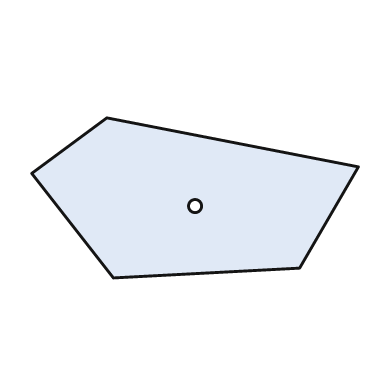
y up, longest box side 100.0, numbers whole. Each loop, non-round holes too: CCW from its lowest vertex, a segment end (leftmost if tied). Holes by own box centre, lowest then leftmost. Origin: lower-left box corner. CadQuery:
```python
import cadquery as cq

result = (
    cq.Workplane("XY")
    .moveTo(25.0, 0.0)
    .lineTo(82.0, 3.0)
    .lineTo(100.0, 34.0)
    .lineTo(23.0, 49.0)
    .lineTo(0.0, 32.0)
    .close()
    .moveTo(50.0, 22.0)
    .circle(2.0)
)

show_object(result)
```